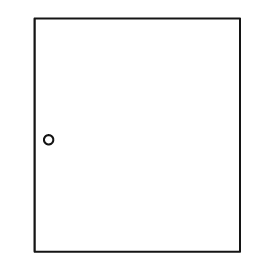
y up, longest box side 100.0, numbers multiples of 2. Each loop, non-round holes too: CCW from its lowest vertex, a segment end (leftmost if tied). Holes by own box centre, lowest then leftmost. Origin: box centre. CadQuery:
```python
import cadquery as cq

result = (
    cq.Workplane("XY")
    .moveTo(-44.0, -50.0)
    .lineTo(44.0, -50.0)
    .lineTo(44.0, 50.0)
    .lineTo(-44.0, 50.0)
    .close()
    .moveTo(-38.0, -2.0)
    .circle(2.0)
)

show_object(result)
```